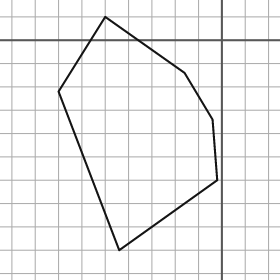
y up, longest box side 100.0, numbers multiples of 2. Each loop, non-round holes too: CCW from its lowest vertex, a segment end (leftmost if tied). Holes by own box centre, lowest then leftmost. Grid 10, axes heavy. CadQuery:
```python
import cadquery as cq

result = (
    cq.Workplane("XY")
    .moveTo(-44.0, -90.0)
    .lineTo(-2.0, -60.0)
    .lineTo(-4.0, -34.0)
    .lineTo(-16.0, -14.0)
    .lineTo(-50.0, 10.0)
    .lineTo(-70.0, -22.0)
    .close()
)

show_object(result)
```